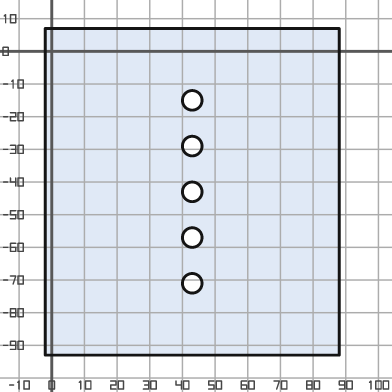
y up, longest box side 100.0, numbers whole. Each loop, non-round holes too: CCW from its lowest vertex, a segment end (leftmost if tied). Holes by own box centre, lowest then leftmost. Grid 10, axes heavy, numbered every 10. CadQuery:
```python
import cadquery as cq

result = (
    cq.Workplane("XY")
    .moveTo(-2.0, -93.0)
    .lineTo(88.0, -93.0)
    .lineTo(88.0, 7.0)
    .lineTo(-2.0, 7.0)
    .close()
    .moveTo(43.0, -71.0)
    .circle(3.0)
    .moveTo(43.0, -57.0)
    .circle(3.0)
    .moveTo(43.0, -43.0)
    .circle(3.0)
    .moveTo(43.0, -29.0)
    .circle(3.0)
    .moveTo(43.0, -15.0)
    .circle(3.0)
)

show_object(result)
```